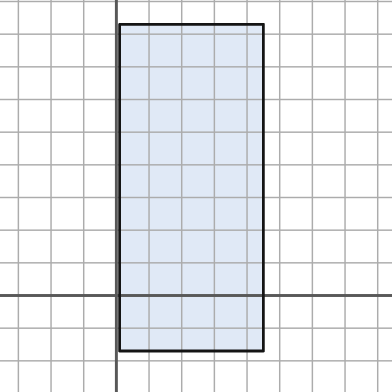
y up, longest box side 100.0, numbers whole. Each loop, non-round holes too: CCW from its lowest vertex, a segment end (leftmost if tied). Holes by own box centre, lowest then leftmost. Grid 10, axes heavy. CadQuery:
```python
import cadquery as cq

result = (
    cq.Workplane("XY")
    .moveTo(1.0, -17.0)
    .lineTo(45.0, -17.0)
    .lineTo(45.0, 83.0)
    .lineTo(1.0, 83.0)
    .close()
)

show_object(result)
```